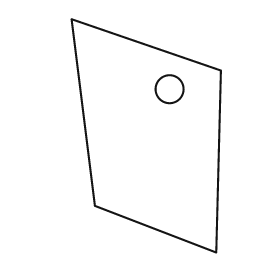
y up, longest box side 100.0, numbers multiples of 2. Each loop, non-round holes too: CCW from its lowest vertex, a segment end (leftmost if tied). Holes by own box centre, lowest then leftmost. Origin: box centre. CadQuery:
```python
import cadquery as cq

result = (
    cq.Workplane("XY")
    .moveTo(30.0, -50.0)
    .lineTo(32.0, 28.0)
    .lineTo(-32.0, 50.0)
    .lineTo(-22.0, -30.0)
    .close()
    .moveTo(10.0, 20.0)
    .circle(6.0)
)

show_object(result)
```